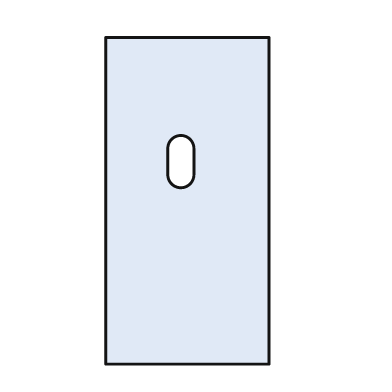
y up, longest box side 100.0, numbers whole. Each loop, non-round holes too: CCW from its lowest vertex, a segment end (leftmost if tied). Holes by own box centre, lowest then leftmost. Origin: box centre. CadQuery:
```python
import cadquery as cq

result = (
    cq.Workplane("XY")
    .moveTo(-25.0, -50.0)
    .lineTo(25.0, -50.0)
    .lineTo(25.0, 50.0)
    .lineTo(-25.0, 50.0)
    .close()
    .moveTo(-6.0, 8.0)
    .threePointArc((-2.0, 4.0), (2.0, 8.0))
    .lineTo(2.0, 16.0)
    .threePointArc((-2.0, 20.0), (-6.0, 16.0))
    .close()
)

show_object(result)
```